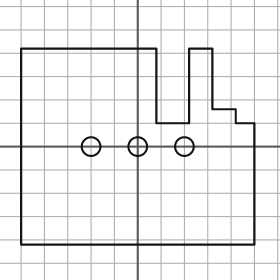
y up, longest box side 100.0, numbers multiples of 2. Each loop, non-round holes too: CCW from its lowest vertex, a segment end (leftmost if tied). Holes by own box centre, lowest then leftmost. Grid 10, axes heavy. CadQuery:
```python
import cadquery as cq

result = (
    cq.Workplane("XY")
    .moveTo(-50.0, -42.0)
    .lineTo(50.0, -42.0)
    .lineTo(50.0, 10.0)
    .lineTo(42.0, 10.0)
    .lineTo(42.0, 16.0)
    .lineTo(32.0, 16.0)
    .lineTo(32.0, 42.0)
    .lineTo(22.0, 42.0)
    .lineTo(22.0, 10.0)
    .lineTo(8.0, 10.0)
    .lineTo(8.0, 42.0)
    .lineTo(-50.0, 42.0)
    .close()
    .moveTo(-20.0, 0.0)
    .circle(4.0)
    .moveTo(0.0, 0.0)
    .circle(4.0)
    .moveTo(20.0, 0.0)
    .circle(4.0)
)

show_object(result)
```